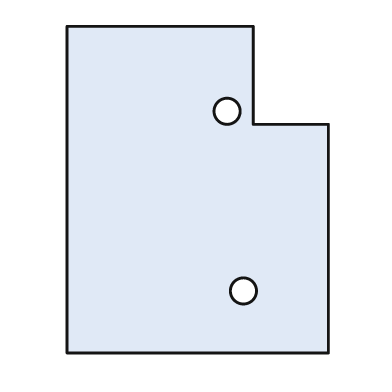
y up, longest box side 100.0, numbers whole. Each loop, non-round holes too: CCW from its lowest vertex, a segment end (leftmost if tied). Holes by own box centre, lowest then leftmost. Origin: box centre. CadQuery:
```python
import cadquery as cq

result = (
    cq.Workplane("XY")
    .moveTo(-40.0, -50.0)
    .lineTo(40.0, -50.0)
    .lineTo(40.0, 20.0)
    .lineTo(17.0, 20.0)
    .lineTo(17.0, 50.0)
    .lineTo(-40.0, 50.0)
    .close()
    .moveTo(14.0, -31.0)
    .circle(4.0)
    .moveTo(9.0, 24.0)
    .circle(4.0)
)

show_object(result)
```